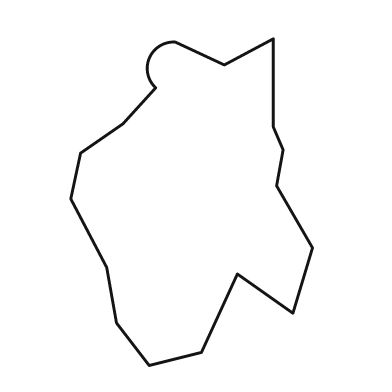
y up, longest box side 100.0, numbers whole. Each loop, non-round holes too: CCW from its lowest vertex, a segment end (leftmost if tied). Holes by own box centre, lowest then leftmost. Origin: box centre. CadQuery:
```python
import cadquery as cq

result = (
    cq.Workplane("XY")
    .moveTo(-13.0, -50.0)
    .lineTo(3.0, -46.0)
    .lineTo(14.0, -22.0)
    .lineTo(31.0, -34.0)
    .lineTo(37.0, -14.0)
    .lineTo(26.0, 5.0)
    .lineTo(28.0, 16.0)
    .lineTo(25.0, 23.0)
    .lineTo(25.0, 50.0)
    .lineTo(10.0, 42.0)
    .lineTo(-5.0, 49.0)
    .threePointArc((-13.0, 44.0), (-11.0, 35.0))
    .lineTo(-21.0, 24.0)
    .lineTo(-34.0, 15.0)
    .lineTo(-37.0, 1.0)
    .lineTo(-26.0, -20.0)
    .lineTo(-23.0, -37.0)
    .close()
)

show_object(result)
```